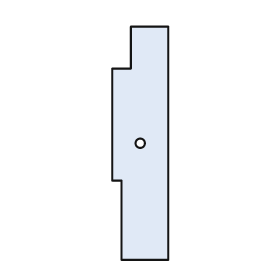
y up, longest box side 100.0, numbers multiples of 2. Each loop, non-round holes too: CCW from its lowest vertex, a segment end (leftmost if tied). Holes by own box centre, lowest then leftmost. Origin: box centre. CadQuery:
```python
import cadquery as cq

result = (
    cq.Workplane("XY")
    .moveTo(-8.0, -50.0)
    .lineTo(12.0, -50.0)
    .lineTo(12.0, 50.0)
    .lineTo(-4.0, 50.0)
    .lineTo(-4.0, 32.0)
    .lineTo(-12.0, 32.0)
    .lineTo(-12.0, -16.0)
    .lineTo(-8.0, -16.0)
    .close()
    .moveTo(0.0, 0.0)
    .circle(2.0)
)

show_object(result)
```